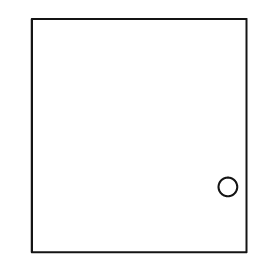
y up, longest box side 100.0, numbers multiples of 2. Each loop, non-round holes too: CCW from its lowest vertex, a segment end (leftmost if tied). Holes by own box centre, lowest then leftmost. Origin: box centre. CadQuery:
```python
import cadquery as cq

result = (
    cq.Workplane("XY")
    .moveTo(-46.0, -50.0)
    .lineTo(46.0, -50.0)
    .lineTo(46.0, 50.0)
    .lineTo(-46.0, 50.0)
    .close()
    .moveTo(38.0, -22.0)
    .circle(4.0)
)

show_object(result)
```